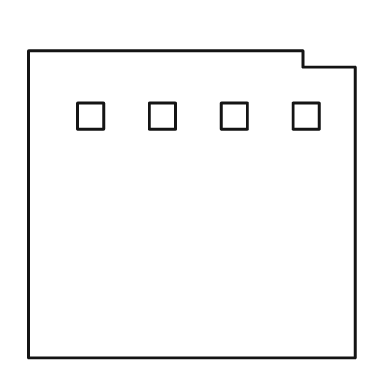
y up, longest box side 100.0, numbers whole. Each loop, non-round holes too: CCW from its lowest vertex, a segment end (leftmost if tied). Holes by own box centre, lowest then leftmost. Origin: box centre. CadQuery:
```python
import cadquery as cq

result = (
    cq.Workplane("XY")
    .moveTo(-50.0, -47.0)
    .lineTo(50.0, -47.0)
    .lineTo(50.0, 42.0)
    .lineTo(34.0, 42.0)
    .lineTo(34.0, 47.0)
    .lineTo(-50.0, 47.0)
    .close()
    .moveTo(-35.0, 23.0)
    .lineTo(-27.0, 23.0)
    .lineTo(-27.0, 31.0)
    .lineTo(-35.0, 31.0)
    .close()
    .moveTo(-13.0, 23.0)
    .lineTo(-5.0, 23.0)
    .lineTo(-5.0, 31.0)
    .lineTo(-13.0, 31.0)
    .close()
    .moveTo(9.0, 23.0)
    .lineTo(17.0, 23.0)
    .lineTo(17.0, 31.0)
    .lineTo(9.0, 31.0)
    .close()
    .moveTo(31.0, 23.0)
    .lineTo(39.0, 23.0)
    .lineTo(39.0, 31.0)
    .lineTo(31.0, 31.0)
    .close()
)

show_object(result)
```